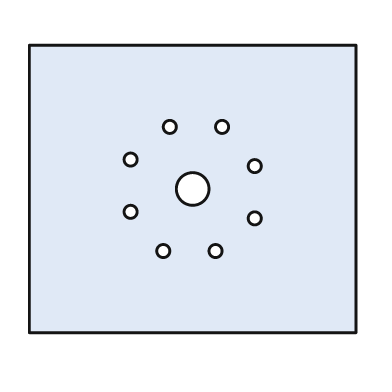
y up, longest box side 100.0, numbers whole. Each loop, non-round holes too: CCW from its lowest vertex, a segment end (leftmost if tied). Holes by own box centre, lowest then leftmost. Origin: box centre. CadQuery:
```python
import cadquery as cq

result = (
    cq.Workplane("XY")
    .moveTo(-50.0, -44.0)
    .lineTo(50.0, -44.0)
    .lineTo(50.0, 44.0)
    .lineTo(-50.0, 44.0)
    .close()
    .moveTo(-9.0, -19.0)
    .circle(2.0)
    .moveTo(7.0, -19.0)
    .circle(2.0)
    .moveTo(19.0, -9.0)
    .circle(2.0)
    .moveTo(-19.0, -7.0)
    .circle(2.0)
    .moveTo(0.0, 0.0)
    .circle(5.0)
    .moveTo(19.0, 7.0)
    .circle(2.0)
    .moveTo(-19.0, 9.0)
    .circle(2.0)
    .moveTo(-7.0, 19.0)
    .circle(2.0)
    .moveTo(9.0, 19.0)
    .circle(2.0)
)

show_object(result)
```